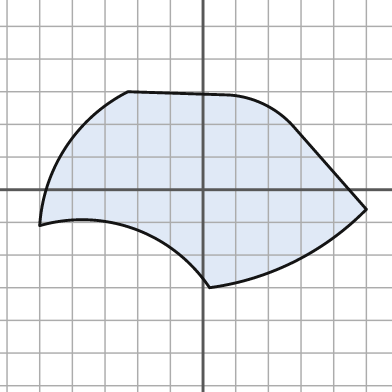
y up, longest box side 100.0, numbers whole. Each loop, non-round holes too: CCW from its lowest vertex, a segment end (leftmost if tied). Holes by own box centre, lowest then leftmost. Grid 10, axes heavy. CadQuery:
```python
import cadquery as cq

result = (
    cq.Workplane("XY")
    .moveTo(2.0, -30.0)
    .threePointArc((28.0, -22.0), (50.0, -6.0))
    .lineTo(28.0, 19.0)
    .threePointArc((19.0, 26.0), (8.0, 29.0))
    .lineTo(-23.0, 30.0)
    .threePointArc((-42.0, 13.0), (-50.0, -11.0))
    .threePointArc((-21.0, -12.0), (2.0, -30.0))
    .close()
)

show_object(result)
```